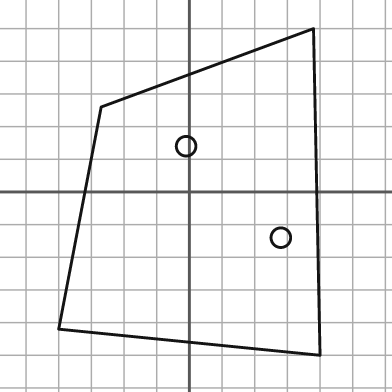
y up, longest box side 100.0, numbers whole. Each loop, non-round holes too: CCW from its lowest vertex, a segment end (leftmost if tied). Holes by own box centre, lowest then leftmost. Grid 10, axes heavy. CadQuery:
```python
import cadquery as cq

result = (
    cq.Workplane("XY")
    .moveTo(40.0, -50.0)
    .lineTo(38.0, 50.0)
    .lineTo(-27.0, 26.0)
    .lineTo(-40.0, -42.0)
    .close()
    .moveTo(28.0, -14.0)
    .circle(3.0)
    .moveTo(-1.0, 14.0)
    .circle(3.0)
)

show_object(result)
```